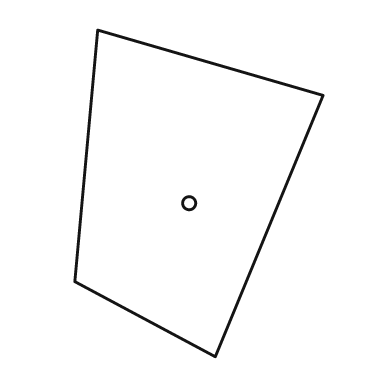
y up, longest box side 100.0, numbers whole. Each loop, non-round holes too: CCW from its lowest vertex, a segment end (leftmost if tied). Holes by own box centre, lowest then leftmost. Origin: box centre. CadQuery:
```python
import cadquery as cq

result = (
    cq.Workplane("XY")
    .moveTo(5.0, -50.0)
    .lineTo(38.0, 30.0)
    .lineTo(-31.0, 50.0)
    .lineTo(-38.0, -27.0)
    .close()
    .moveTo(-3.0, -3.0)
    .circle(2.0)
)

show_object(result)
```